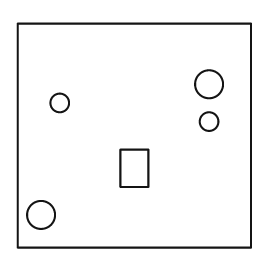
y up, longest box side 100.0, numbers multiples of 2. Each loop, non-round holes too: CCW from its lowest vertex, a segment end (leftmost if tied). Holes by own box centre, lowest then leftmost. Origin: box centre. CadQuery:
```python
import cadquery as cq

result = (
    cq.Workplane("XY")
    .moveTo(-50.0, -48.0)
    .lineTo(50.0, -48.0)
    .lineTo(50.0, 48.0)
    .lineTo(-50.0, 48.0)
    .close()
    .moveTo(-40.0, -34.0)
    .circle(6.0)
    .moveTo(-6.0, -22.0)
    .lineTo(6.0, -22.0)
    .lineTo(6.0, -6.0)
    .lineTo(-6.0, -6.0)
    .close()
    .moveTo(32.0, 6.0)
    .circle(4.0)
    .moveTo(-32.0, 14.0)
    .circle(4.0)
    .moveTo(32.0, 22.0)
    .circle(6.0)
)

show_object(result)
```